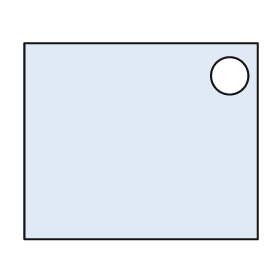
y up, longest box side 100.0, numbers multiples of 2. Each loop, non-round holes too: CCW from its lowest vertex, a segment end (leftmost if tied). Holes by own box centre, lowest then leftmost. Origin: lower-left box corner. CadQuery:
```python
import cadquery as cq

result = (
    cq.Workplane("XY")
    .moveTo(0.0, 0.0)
    .lineTo(100.0, 0.0)
    .lineTo(100.0, 84.0)
    .lineTo(0.0, 84.0)
    .close()
    .moveTo(88.0, 70.0)
    .circle(8.0)
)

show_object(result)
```